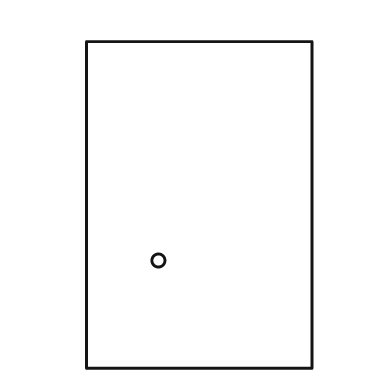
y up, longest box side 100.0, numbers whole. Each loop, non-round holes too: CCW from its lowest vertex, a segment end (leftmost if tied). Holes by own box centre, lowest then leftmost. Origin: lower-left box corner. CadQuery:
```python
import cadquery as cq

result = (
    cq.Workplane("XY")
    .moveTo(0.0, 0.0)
    .lineTo(69.0, 0.0)
    .lineTo(69.0, 100.0)
    .lineTo(0.0, 100.0)
    .close()
    .moveTo(22.0, 33.0)
    .circle(2.0)
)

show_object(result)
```